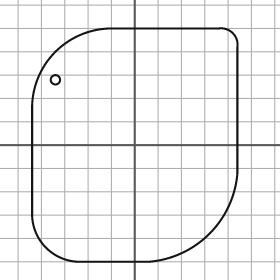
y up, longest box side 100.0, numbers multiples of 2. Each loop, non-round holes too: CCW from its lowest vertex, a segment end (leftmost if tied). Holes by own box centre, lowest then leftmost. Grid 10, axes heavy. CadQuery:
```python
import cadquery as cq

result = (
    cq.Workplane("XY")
    .moveTo(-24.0, -50.0)
    .lineTo(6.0, -50.0)
    .threePointArc((32.0, -38.0), (44.0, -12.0))
    .lineTo(44.0, 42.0)
    .threePointArc((42.0, 48.0), (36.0, 50.0))
    .lineTo(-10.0, 50.0)
    .threePointArc((-34.0, 40.0), (-44.0, 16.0))
    .lineTo(-44.0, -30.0)
    .threePointArc((-38.0, -44.0), (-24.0, -50.0))
    .close()
    .moveTo(-34.0, 28.0)
    .circle(2.0)
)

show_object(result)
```